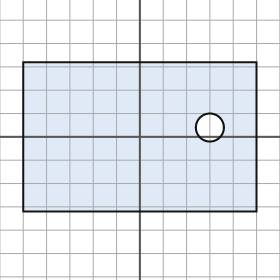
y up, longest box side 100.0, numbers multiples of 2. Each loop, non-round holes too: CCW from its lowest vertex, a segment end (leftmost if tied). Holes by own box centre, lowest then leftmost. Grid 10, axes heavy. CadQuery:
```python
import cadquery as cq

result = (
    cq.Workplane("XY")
    .moveTo(-50.0, -32.0)
    .lineTo(50.0, -32.0)
    .lineTo(50.0, 32.0)
    .lineTo(-50.0, 32.0)
    .close()
    .moveTo(30.0, 4.0)
    .circle(6.0)
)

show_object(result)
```